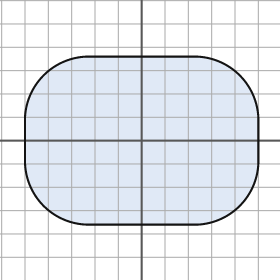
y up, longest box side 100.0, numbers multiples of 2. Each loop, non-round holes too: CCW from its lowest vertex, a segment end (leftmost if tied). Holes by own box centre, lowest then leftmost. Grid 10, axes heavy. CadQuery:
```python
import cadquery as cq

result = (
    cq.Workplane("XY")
    .moveTo(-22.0, -36.0)
    .lineTo(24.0, -36.0)
    .threePointArc((42.0, -28.0), (50.0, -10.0))
    .lineTo(50.0, 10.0)
    .threePointArc((42.0, 28.0), (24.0, 36.0))
    .lineTo(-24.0, 36.0)
    .threePointArc((-42.0, 28.0), (-50.0, 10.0))
    .lineTo(-50.0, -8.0)
    .threePointArc((-42.0, -28.0), (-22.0, -36.0))
    .close()
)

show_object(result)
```